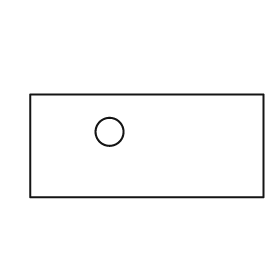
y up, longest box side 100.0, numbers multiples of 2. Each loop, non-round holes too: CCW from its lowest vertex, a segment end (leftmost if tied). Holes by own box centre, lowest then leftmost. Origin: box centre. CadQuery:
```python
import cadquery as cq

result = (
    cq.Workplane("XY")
    .moveTo(-50.0, -22.0)
    .lineTo(50.0, -22.0)
    .lineTo(50.0, 22.0)
    .lineTo(-50.0, 22.0)
    .close()
    .moveTo(-16.0, 6.0)
    .circle(6.0)
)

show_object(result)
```